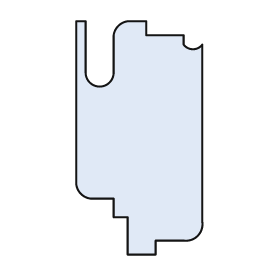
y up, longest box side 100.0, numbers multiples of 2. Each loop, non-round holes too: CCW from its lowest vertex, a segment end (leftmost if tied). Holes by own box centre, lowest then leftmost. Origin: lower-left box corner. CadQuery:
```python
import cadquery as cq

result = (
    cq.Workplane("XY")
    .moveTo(22.0, 0.0)
    .lineTo(34.0, 0.0)
    .lineTo(34.0, 6.0)
    .lineTo(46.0, 6.0)
    .threePointArc((52.0, 8.0), (54.0, 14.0))
    .lineTo(54.0, 90.0)
    .threePointArc((50.0, 88.0), (46.0, 90.0))
    .lineTo(46.0, 94.0)
    .lineTo(30.0, 94.0)
    .lineTo(30.0, 100.0)
    .lineTo(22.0, 100.0)
    .threePointArc((18.0, 98.0), (16.0, 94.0))
    .lineTo(16.0, 78.0)
    .threePointArc((10.0, 72.0), (4.0, 78.0))
    .lineTo(4.0, 100.0)
    .lineTo(0.0, 100.0)
    .lineTo(0.0, 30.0)
    .threePointArc((2.0, 26.0), (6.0, 24.0))
    .lineTo(16.0, 24.0)
    .lineTo(16.0, 16.0)
    .lineTo(22.0, 16.0)
    .close()
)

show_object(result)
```